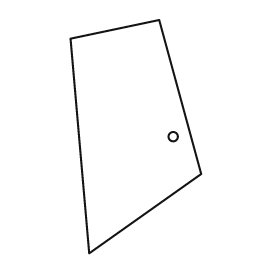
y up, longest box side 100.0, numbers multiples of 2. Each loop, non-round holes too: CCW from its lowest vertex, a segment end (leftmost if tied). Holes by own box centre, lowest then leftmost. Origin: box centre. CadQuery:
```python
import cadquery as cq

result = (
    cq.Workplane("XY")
    .moveTo(-20.0, -50.0)
    .lineTo(28.0, -16.0)
    .lineTo(10.0, 50.0)
    .lineTo(-28.0, 42.0)
    .close()
    .moveTo(16.0, 0.0)
    .circle(2.0)
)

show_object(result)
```